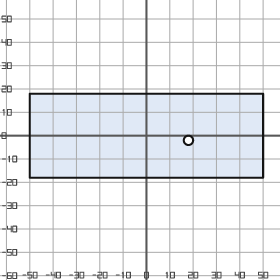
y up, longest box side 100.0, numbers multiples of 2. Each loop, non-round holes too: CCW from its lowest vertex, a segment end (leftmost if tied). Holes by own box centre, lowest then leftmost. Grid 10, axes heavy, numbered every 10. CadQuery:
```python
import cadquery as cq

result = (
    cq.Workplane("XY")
    .moveTo(-50.0, -18.0)
    .lineTo(50.0, -18.0)
    .lineTo(50.0, 18.0)
    .lineTo(-50.0, 18.0)
    .close()
    .moveTo(18.0, -2.0)
    .circle(2.0)
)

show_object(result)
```